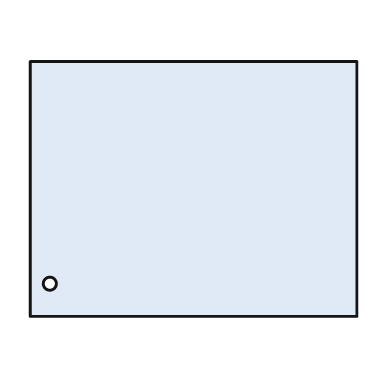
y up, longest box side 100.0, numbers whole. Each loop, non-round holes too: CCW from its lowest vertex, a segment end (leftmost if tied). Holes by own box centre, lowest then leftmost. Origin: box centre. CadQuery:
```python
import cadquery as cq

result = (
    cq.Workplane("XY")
    .moveTo(-50.0, -39.0)
    .lineTo(50.0, -39.0)
    .lineTo(50.0, 39.0)
    .lineTo(-50.0, 39.0)
    .close()
    .moveTo(-44.0, -29.0)
    .circle(2.0)
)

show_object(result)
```